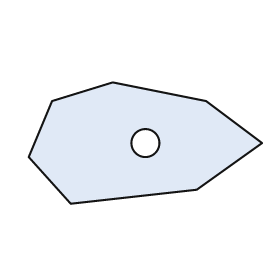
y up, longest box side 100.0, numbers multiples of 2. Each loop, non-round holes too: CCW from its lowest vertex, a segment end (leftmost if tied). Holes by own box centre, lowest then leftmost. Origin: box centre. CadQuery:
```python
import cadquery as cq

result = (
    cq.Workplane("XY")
    .moveTo(-32.0, -26.0)
    .lineTo(22.0, -20.0)
    .lineTo(50.0, 0.0)
    .lineTo(26.0, 18.0)
    .lineTo(-14.0, 26.0)
    .lineTo(-40.0, 18.0)
    .lineTo(-50.0, -6.0)
    .close()
    .moveTo(0.0, 0.0)
    .circle(6.0)
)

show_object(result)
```